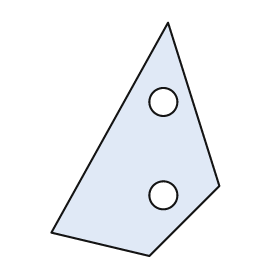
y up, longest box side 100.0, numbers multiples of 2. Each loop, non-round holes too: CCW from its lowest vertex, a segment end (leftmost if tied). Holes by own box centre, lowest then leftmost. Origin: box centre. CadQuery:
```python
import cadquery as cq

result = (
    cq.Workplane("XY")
    .moveTo(6.0, -50.0)
    .lineTo(36.0, -20.0)
    .lineTo(14.0, 50.0)
    .lineTo(-36.0, -40.0)
    .close()
    .moveTo(12.0, -24.0)
    .circle(6.0)
    .moveTo(12.0, 16.0)
    .circle(6.0)
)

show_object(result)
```